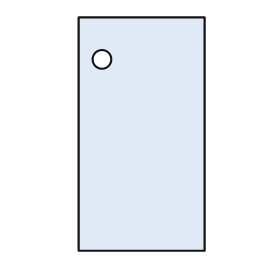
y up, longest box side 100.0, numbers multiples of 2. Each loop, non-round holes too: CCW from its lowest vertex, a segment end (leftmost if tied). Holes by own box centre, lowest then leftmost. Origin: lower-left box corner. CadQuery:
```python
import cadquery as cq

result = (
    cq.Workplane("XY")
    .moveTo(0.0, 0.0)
    .lineTo(54.0, 0.0)
    .lineTo(54.0, 100.0)
    .lineTo(0.0, 100.0)
    .close()
    .moveTo(10.0, 82.0)
    .circle(4.0)
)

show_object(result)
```